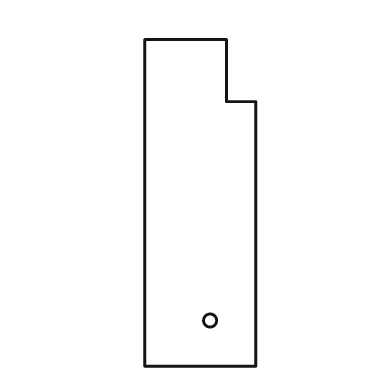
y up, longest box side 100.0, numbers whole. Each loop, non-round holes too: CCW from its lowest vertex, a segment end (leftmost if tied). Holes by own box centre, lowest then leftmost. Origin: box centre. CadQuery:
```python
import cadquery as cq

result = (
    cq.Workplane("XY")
    .moveTo(-17.0, -50.0)
    .lineTo(17.0, -50.0)
    .lineTo(17.0, 31.0)
    .lineTo(8.0, 31.0)
    .lineTo(8.0, 50.0)
    .lineTo(-17.0, 50.0)
    .close()
    .moveTo(3.0, -36.0)
    .circle(2.0)
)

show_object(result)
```